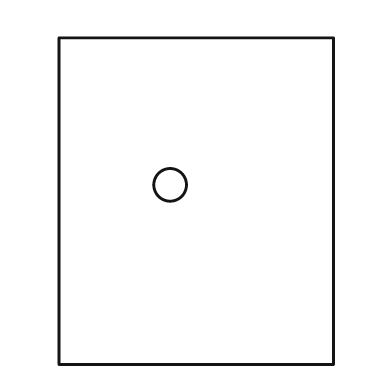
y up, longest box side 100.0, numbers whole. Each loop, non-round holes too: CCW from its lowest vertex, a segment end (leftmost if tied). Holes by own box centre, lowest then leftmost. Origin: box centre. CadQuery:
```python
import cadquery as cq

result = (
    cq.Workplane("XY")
    .moveTo(-42.0, -50.0)
    .lineTo(42.0, -50.0)
    .lineTo(42.0, 50.0)
    .lineTo(-42.0, 50.0)
    .close()
    .moveTo(-8.0, 5.0)
    .circle(5.0)
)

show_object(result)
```